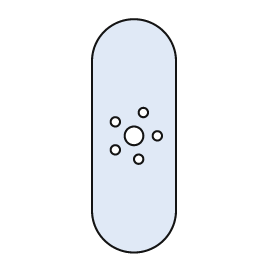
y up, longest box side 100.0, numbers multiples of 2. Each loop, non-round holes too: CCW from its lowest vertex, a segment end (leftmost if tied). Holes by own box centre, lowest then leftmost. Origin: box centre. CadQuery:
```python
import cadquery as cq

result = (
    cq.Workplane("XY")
    .moveTo(-18.0, -32.0)
    .threePointArc((0.0, -50.0), (18.0, -32.0))
    .lineTo(18.0, 32.0)
    .threePointArc((0.0, 50.0), (-18.0, 32.0))
    .close()
    .moveTo(2.0, -10.0)
    .circle(2.0)
    .moveTo(-8.0, -6.0)
    .circle(2.0)
    .moveTo(0.0, 0.0)
    .circle(4.0)
    .moveTo(10.0, 0.0)
    .circle(2.0)
    .moveTo(-8.0, 6.0)
    .circle(2.0)
    .moveTo(4.0, 10.0)
    .circle(2.0)
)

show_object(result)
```